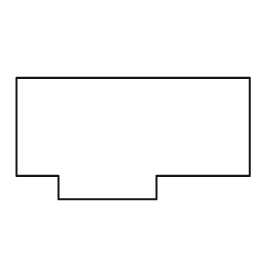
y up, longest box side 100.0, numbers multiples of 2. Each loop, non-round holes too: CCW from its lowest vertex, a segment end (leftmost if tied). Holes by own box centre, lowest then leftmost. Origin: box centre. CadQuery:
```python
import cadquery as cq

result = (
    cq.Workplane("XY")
    .moveTo(-32.0, -26.0)
    .lineTo(10.0, -26.0)
    .lineTo(10.0, -16.0)
    .lineTo(50.0, -16.0)
    .lineTo(50.0, 26.0)
    .lineTo(-50.0, 26.0)
    .lineTo(-50.0, -16.0)
    .lineTo(-32.0, -16.0)
    .close()
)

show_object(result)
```